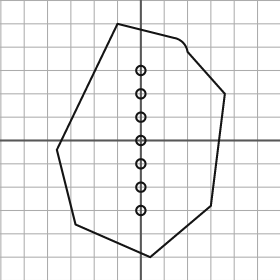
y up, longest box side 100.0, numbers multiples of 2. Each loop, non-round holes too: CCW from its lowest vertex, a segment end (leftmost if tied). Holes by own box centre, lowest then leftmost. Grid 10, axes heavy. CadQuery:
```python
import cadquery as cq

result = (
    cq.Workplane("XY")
    .moveTo(4.0, -50.0)
    .lineTo(30.0, -28.0)
    .lineTo(36.0, 20.0)
    .lineTo(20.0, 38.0)
    .threePointArc((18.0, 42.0), (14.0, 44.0))
    .lineTo(-10.0, 50.0)
    .lineTo(-36.0, -4.0)
    .lineTo(-28.0, -36.0)
    .close()
    .moveTo(0.0, -30.0)
    .circle(2.0)
    .moveTo(0.0, -20.0)
    .circle(2.0)
    .moveTo(0.0, -10.0)
    .circle(2.0)
    .moveTo(0.0, 0.0)
    .circle(2.0)
    .moveTo(0.0, 10.0)
    .circle(2.0)
    .moveTo(0.0, 20.0)
    .circle(2.0)
    .moveTo(0.0, 30.0)
    .circle(2.0)
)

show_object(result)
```